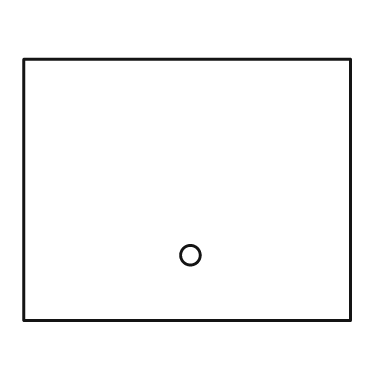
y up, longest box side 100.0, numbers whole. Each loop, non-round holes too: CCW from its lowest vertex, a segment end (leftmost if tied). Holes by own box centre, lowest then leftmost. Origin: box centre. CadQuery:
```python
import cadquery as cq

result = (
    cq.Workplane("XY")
    .moveTo(-50.0, -40.0)
    .lineTo(50.0, -40.0)
    .lineTo(50.0, 40.0)
    .lineTo(-50.0, 40.0)
    .close()
    .moveTo(1.0, -20.0)
    .circle(3.0)
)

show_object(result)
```